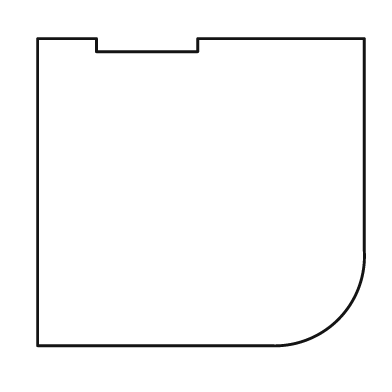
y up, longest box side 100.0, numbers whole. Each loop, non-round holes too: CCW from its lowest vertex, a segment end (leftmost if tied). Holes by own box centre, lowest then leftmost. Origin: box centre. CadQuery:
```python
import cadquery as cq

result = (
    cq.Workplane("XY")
    .moveTo(-50.0, -47.0)
    .lineTo(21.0, -47.0)
    .threePointArc((42.0, -39.0), (50.0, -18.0))
    .lineTo(50.0, 47.0)
    .lineTo(-1.0, 47.0)
    .lineTo(-1.0, 43.0)
    .lineTo(-32.0, 43.0)
    .lineTo(-32.0, 47.0)
    .lineTo(-50.0, 47.0)
    .close()
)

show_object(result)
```